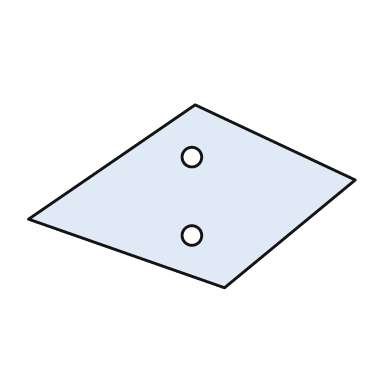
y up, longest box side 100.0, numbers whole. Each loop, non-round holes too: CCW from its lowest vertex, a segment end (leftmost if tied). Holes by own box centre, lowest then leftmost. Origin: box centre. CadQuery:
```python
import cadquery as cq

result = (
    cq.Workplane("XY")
    .moveTo(10.0, -28.0)
    .lineTo(50.0, 5.0)
    .lineTo(1.0, 28.0)
    .lineTo(-50.0, -7.0)
    .close()
    .moveTo(0.0, -12.0)
    .circle(3.0)
    .moveTo(0.0, 12.0)
    .circle(3.0)
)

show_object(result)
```